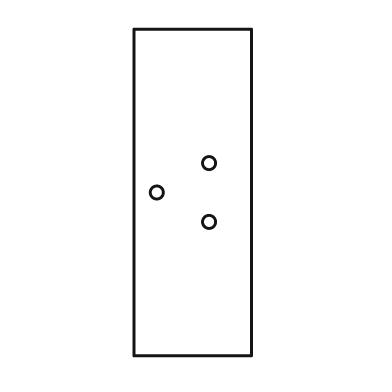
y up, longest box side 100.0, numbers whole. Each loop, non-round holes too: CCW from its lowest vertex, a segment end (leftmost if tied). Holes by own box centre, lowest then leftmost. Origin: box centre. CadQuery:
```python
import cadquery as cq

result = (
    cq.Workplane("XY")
    .moveTo(-18.0, -50.0)
    .lineTo(18.0, -50.0)
    .lineTo(18.0, 50.0)
    .lineTo(-18.0, 50.0)
    .close()
    .moveTo(5.0, -9.0)
    .circle(2.0)
    .moveTo(-11.0, 0.0)
    .circle(2.0)
    .moveTo(5.0, 9.0)
    .circle(2.0)
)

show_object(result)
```